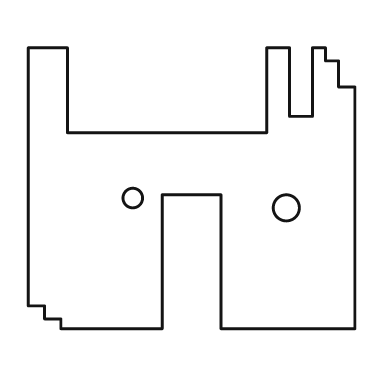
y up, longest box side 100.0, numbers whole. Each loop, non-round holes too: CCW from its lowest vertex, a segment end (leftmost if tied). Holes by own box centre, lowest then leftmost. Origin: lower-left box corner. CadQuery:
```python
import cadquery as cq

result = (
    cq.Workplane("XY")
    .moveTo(10.0, 0.0)
    .lineTo(41.0, 0.0)
    .lineTo(41.0, 41.0)
    .lineTo(59.0, 41.0)
    .lineTo(59.0, 0.0)
    .lineTo(100.0, 0.0)
    .lineTo(100.0, 74.0)
    .lineTo(95.0, 74.0)
    .lineTo(95.0, 82.0)
    .lineTo(91.0, 82.0)
    .lineTo(91.0, 86.0)
    .lineTo(87.0, 86.0)
    .lineTo(87.0, 65.0)
    .lineTo(80.0, 65.0)
    .lineTo(80.0, 86.0)
    .lineTo(73.0, 86.0)
    .lineTo(73.0, 60.0)
    .lineTo(12.0, 60.0)
    .lineTo(12.0, 86.0)
    .lineTo(0.0, 86.0)
    .lineTo(0.0, 7.0)
    .lineTo(5.0, 7.0)
    .lineTo(5.0, 3.0)
    .lineTo(10.0, 3.0)
    .close()
    .moveTo(79.0, 37.0)
    .circle(4.0)
    .moveTo(32.0, 40.0)
    .circle(3.0)
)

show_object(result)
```